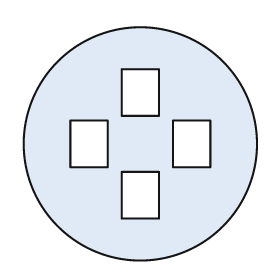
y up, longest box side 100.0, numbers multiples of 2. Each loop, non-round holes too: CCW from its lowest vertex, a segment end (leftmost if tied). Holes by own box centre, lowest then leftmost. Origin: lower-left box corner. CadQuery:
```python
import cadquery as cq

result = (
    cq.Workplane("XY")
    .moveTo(50.0, 50.0)
    .circle(50.0)
    .moveTo(42.0, 18.0)
    .lineTo(58.0, 18.0)
    .lineTo(58.0, 38.0)
    .lineTo(42.0, 38.0)
    .close()
    .moveTo(20.0, 40.0)
    .lineTo(36.0, 40.0)
    .lineTo(36.0, 60.0)
    .lineTo(20.0, 60.0)
    .close()
    .moveTo(64.0, 40.0)
    .lineTo(80.0, 40.0)
    .lineTo(80.0, 60.0)
    .lineTo(64.0, 60.0)
    .close()
    .moveTo(42.0, 62.0)
    .lineTo(58.0, 62.0)
    .lineTo(58.0, 82.0)
    .lineTo(42.0, 82.0)
    .close()
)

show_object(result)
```